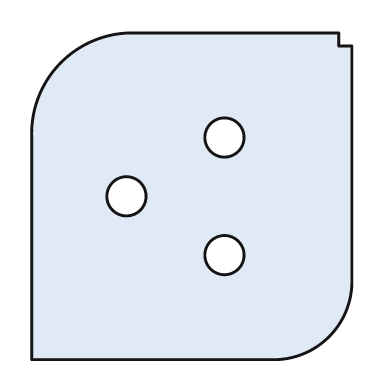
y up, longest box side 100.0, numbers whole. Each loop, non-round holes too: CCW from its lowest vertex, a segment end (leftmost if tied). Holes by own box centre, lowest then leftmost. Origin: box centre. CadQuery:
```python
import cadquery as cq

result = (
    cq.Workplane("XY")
    .moveTo(-49.0, -50.0)
    .lineTo(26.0, -50.0)
    .threePointArc((42.0, -43.0), (49.0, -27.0))
    .lineTo(49.0, 46.0)
    .lineTo(45.0, 46.0)
    .lineTo(45.0, 50.0)
    .lineTo(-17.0, 50.0)
    .threePointArc((-40.0, 41.0), (-49.0, 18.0))
    .close()
    .moveTo(10.0, -18.0)
    .circle(6.0)
    .moveTo(-20.0, 0.0)
    .circle(6.0)
    .moveTo(10.0, 18.0)
    .circle(6.0)
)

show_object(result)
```